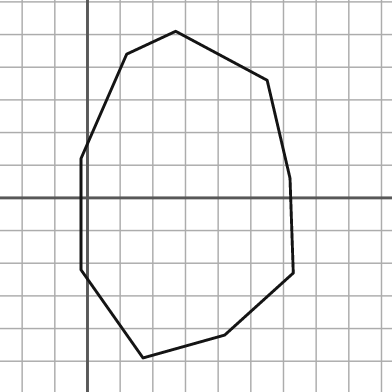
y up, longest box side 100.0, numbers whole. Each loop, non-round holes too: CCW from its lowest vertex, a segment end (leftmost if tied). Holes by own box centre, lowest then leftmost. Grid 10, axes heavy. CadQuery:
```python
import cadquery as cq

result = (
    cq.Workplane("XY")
    .moveTo(17.0, -49.0)
    .lineTo(42.0, -42.0)
    .lineTo(63.0, -23.0)
    .lineTo(62.0, 6.0)
    .lineTo(55.0, 36.0)
    .lineTo(27.0, 51.0)
    .lineTo(12.0, 44.0)
    .lineTo(-2.0, 12.0)
    .lineTo(-2.0, -22.0)
    .close()
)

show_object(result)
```